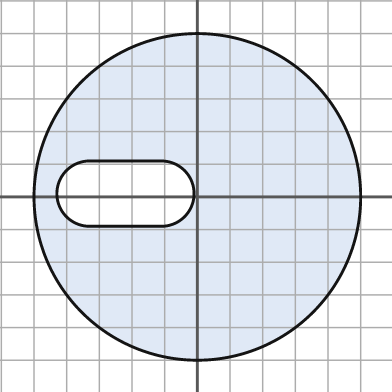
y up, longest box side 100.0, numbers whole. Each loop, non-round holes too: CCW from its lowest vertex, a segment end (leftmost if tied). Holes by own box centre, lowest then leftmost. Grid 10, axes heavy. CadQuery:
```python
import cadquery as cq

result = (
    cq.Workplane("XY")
    .moveTo(0.0, 0.0)
    .circle(50.0)
    .moveTo(-33.0, -9.0)
    .lineTo(-11.0, -9.0)
    .threePointArc((-1.0, 1.0), (-11.0, 11.0))
    .lineTo(-33.0, 11.0)
    .threePointArc((-43.0, 1.0), (-33.0, -9.0))
    .close()
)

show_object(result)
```